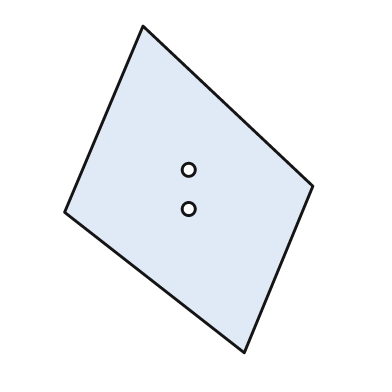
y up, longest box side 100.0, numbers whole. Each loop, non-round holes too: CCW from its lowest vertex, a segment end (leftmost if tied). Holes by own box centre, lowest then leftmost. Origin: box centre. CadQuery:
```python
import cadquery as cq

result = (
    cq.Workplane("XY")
    .moveTo(17.0, -50.0)
    .lineTo(38.0, 1.0)
    .lineTo(-14.0, 50.0)
    .lineTo(-38.0, -7.0)
    .close()
    .moveTo(0.0, -6.0)
    .circle(2.0)
    .moveTo(0.0, 6.0)
    .circle(2.0)
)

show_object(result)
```